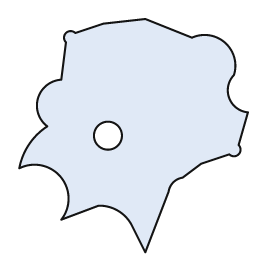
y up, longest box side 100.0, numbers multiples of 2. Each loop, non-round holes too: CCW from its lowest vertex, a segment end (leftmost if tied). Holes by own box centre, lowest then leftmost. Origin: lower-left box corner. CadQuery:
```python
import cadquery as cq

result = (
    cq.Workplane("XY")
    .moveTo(54.0, 0.0)
    .lineTo(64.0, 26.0)
    .threePointArc((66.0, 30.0), (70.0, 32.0))
    .lineTo(78.0, 38.0)
    .lineTo(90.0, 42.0)
    .threePointArc((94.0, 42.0), (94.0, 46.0))
    .lineTo(98.0, 60.0)
    .threePointArc((90.0, 66.0), (92.0, 76.0))
    .threePointArc((88.0, 90.0), (74.0, 92.0))
    .lineTo(54.0, 100.0)
    .lineTo(36.0, 98.0)
    .lineTo(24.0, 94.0)
    .threePointArc((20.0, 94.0), (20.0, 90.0))
    .lineTo(18.0, 74.0)
    .threePointArc((8.0, 66.0), (12.0, 54.0))
    .threePointArc((4.0, 46.0), (0.0, 36.0))
    .threePointArc((18.0, 32.0), (18.0, 14.0))
    .lineTo(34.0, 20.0)
    .threePointArc((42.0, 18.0), (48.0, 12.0))
    .close()
    .moveTo(38.0, 50.0)
    .circle(6.0)
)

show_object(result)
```